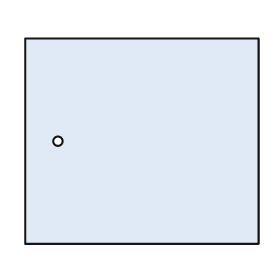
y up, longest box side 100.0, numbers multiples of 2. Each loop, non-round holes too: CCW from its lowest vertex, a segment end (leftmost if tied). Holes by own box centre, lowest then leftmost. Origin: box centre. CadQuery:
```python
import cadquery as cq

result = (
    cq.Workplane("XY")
    .moveTo(-50.0, -44.0)
    .lineTo(50.0, -44.0)
    .lineTo(50.0, 44.0)
    .lineTo(-50.0, 44.0)
    .close()
    .moveTo(-36.0, 0.0)
    .circle(2.0)
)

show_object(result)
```